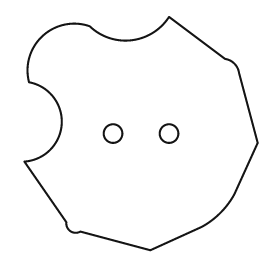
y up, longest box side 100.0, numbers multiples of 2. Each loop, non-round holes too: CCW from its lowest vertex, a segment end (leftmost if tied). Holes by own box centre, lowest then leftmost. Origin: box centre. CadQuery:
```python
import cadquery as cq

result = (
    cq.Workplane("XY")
    .moveTo(4.0, -50.0)
    .lineTo(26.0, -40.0)
    .threePointArc((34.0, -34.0), (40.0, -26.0))
    .lineTo(50.0, -4.0)
    .lineTo(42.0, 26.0)
    .threePointArc((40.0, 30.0), (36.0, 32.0))
    .lineTo(12.0, 50.0)
    .threePointArc((-4.0, 40.0), (-22.0, 46.0))
    .threePointArc((-42.0, 42.0), (-48.0, 22.0))
    .threePointArc((-34.0, 4.0), (-50.0, -12.0))
    .lineTo(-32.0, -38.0)
    .threePointArc((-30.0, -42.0), (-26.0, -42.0))
    .close()
    .moveTo(-12.0, 0.0)
    .circle(4.0)
    .moveTo(12.0, 0.0)
    .circle(4.0)
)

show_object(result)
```